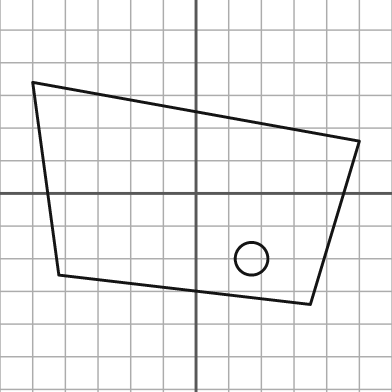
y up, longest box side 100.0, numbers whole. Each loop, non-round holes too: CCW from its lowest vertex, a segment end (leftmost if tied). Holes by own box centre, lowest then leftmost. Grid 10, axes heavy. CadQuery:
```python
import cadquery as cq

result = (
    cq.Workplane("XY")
    .moveTo(35.0, -34.0)
    .lineTo(50.0, 16.0)
    .lineTo(-50.0, 34.0)
    .lineTo(-42.0, -25.0)
    .close()
    .moveTo(17.0, -20.0)
    .circle(5.0)
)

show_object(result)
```